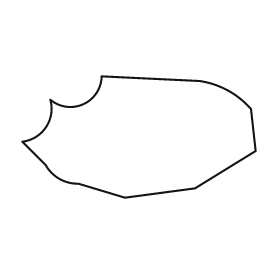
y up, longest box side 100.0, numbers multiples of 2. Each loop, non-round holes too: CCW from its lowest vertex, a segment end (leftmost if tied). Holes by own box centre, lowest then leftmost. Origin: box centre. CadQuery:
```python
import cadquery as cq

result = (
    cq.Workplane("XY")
    .moveTo(-6.0, -26.0)
    .lineTo(24.0, -22.0)
    .lineTo(50.0, -6.0)
    .lineTo(48.0, 12.0)
    .threePointArc((38.0, 20.0), (26.0, 24.0))
    .lineTo(-16.0, 26.0)
    .threePointArc((-24.0, 14.0), (-38.0, 16.0))
    .threePointArc((-40.0, 4.0), (-50.0, -2.0))
    .lineTo(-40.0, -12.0)
    .threePointArc((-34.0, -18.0), (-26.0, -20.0))
    .close()
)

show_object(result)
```